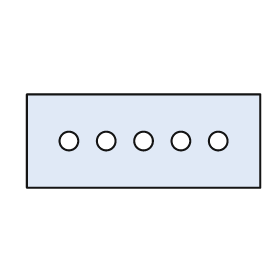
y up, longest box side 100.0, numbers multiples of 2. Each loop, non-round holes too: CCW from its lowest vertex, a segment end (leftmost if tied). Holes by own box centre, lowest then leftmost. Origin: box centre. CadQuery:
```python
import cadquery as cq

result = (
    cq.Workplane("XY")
    .moveTo(-50.0, -20.0)
    .lineTo(50.0, -20.0)
    .lineTo(50.0, 20.0)
    .lineTo(-50.0, 20.0)
    .close()
    .moveTo(-32.0, 0.0)
    .circle(4.0)
    .moveTo(-16.0, 0.0)
    .circle(4.0)
    .moveTo(0.0, 0.0)
    .circle(4.0)
    .moveTo(16.0, 0.0)
    .circle(4.0)
    .moveTo(32.0, 0.0)
    .circle(4.0)
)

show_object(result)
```